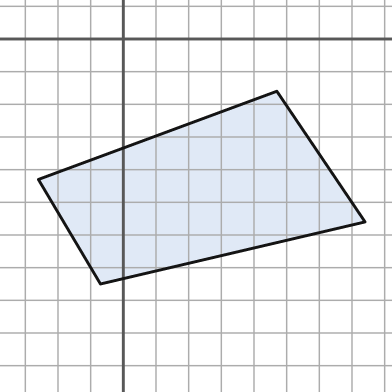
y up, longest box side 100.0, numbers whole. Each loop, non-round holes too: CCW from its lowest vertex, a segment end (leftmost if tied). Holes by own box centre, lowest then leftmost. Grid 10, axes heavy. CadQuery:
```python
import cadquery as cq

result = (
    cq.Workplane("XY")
    .moveTo(-7.0, -75.0)
    .lineTo(74.0, -56.0)
    .lineTo(47.0, -16.0)
    .lineTo(-26.0, -43.0)
    .close()
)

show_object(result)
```